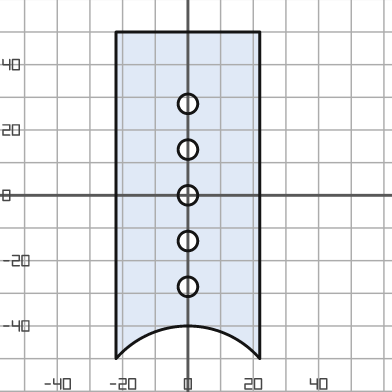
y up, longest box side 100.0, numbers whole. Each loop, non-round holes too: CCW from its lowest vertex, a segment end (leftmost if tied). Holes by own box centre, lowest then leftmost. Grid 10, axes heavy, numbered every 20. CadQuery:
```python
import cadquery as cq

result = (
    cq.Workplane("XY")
    .moveTo(-22.0, -50.0)
    .threePointArc((0.0, -40.0), (22.0, -50.0))
    .lineTo(22.0, 50.0)
    .lineTo(-22.0, 50.0)
    .close()
    .moveTo(0.0, -28.0)
    .circle(3.0)
    .moveTo(0.0, -14.0)
    .circle(3.0)
    .moveTo(0.0, 0.0)
    .circle(3.0)
    .moveTo(0.0, 14.0)
    .circle(3.0)
    .moveTo(0.0, 28.0)
    .circle(3.0)
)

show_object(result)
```